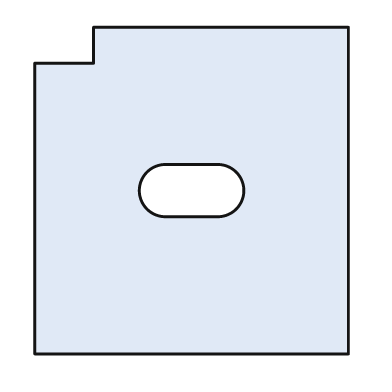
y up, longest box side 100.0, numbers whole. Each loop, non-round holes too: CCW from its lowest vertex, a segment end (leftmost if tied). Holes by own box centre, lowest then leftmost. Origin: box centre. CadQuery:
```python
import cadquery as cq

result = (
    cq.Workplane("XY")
    .moveTo(-48.0, -50.0)
    .lineTo(48.0, -50.0)
    .lineTo(48.0, 50.0)
    .lineTo(-30.0, 50.0)
    .lineTo(-30.0, 39.0)
    .lineTo(-48.0, 39.0)
    .close()
    .moveTo(-8.0, -8.0)
    .lineTo(8.0, -8.0)
    .threePointArc((16.0, 0.0), (8.0, 8.0))
    .lineTo(-8.0, 8.0)
    .threePointArc((-16.0, 0.0), (-8.0, -8.0))
    .close()
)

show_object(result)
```